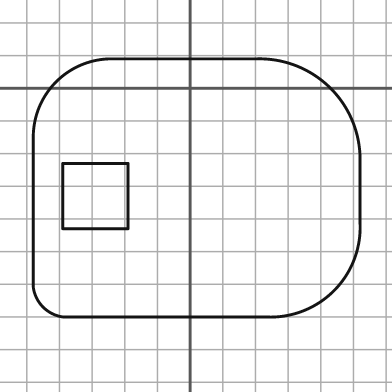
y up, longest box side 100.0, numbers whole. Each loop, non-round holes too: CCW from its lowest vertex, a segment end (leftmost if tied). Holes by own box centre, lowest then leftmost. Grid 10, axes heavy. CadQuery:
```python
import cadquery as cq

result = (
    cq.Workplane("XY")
    .moveTo(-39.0, -70.0)
    .lineTo(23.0, -70.0)
    .threePointArc((44.0, -62.0), (52.0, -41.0))
    .lineTo(52.0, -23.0)
    .threePointArc((43.0, 0.0), (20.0, 9.0))
    .lineTo(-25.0, 9.0)
    .threePointArc((-41.0, 2.0), (-48.0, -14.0))
    .lineTo(-48.0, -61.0)
    .threePointArc((-45.0, -67.0), (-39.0, -70.0))
    .close()
    .moveTo(-39.0, -43.0)
    .lineTo(-19.0, -43.0)
    .lineTo(-19.0, -23.0)
    .lineTo(-39.0, -23.0)
    .close()
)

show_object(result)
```